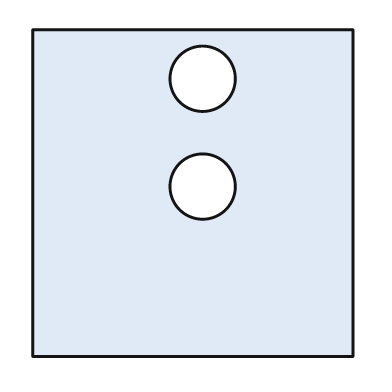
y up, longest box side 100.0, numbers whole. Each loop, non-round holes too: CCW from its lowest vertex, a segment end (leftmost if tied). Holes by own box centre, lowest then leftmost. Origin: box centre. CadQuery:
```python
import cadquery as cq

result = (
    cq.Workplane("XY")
    .moveTo(-49.0, -50.0)
    .lineTo(49.0, -50.0)
    .lineTo(49.0, 50.0)
    .lineTo(-49.0, 50.0)
    .close()
    .moveTo(3.0, 2.0)
    .circle(10.0)
    .moveTo(3.0, 35.0)
    .circle(10.0)
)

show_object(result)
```